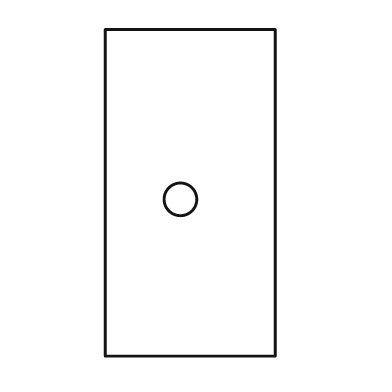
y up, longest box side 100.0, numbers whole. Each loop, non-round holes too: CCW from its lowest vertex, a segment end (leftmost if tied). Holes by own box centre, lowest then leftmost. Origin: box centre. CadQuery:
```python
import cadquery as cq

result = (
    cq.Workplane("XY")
    .moveTo(-26.0, -50.0)
    .lineTo(26.0, -50.0)
    .lineTo(26.0, 50.0)
    .lineTo(-26.0, 50.0)
    .close()
    .moveTo(-3.0, -2.0)
    .circle(5.0)
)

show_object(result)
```